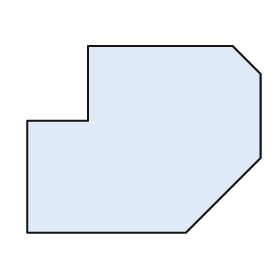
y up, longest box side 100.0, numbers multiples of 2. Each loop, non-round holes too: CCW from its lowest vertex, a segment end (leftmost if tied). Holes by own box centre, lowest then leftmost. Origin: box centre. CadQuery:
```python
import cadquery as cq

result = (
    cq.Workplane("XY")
    .moveTo(-50.0, -40.0)
    .lineTo(18.0, -40.0)
    .lineTo(50.0, -8.0)
    .lineTo(50.0, 28.0)
    .lineTo(38.0, 40.0)
    .lineTo(-24.0, 40.0)
    .lineTo(-24.0, 8.0)
    .lineTo(-50.0, 8.0)
    .close()
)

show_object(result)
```